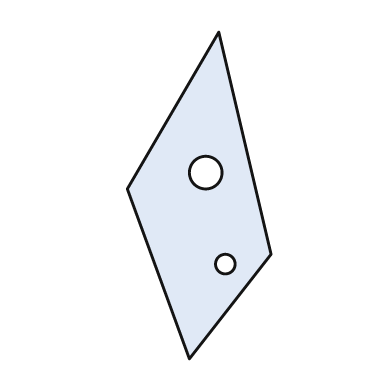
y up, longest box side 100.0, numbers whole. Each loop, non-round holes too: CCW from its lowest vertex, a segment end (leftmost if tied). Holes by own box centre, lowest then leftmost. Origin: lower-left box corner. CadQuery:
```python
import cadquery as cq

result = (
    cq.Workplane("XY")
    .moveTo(19.0, 0.0)
    .lineTo(44.0, 32.0)
    .lineTo(28.0, 100.0)
    .lineTo(0.0, 52.0)
    .close()
    .moveTo(30.0, 29.0)
    .circle(3.0)
    .moveTo(24.0, 57.0)
    .circle(5.0)
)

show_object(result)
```